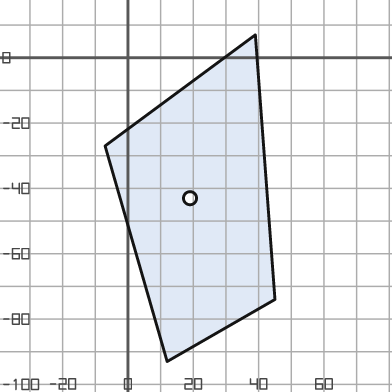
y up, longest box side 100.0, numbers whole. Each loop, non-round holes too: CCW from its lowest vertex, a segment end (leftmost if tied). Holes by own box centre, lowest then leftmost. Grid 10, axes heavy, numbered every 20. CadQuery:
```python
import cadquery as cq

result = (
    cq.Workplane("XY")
    .moveTo(12.0, -93.0)
    .lineTo(45.0, -74.0)
    .lineTo(39.0, 7.0)
    .lineTo(-7.0, -27.0)
    .close()
    .moveTo(19.0, -43.0)
    .circle(2.0)
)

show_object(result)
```